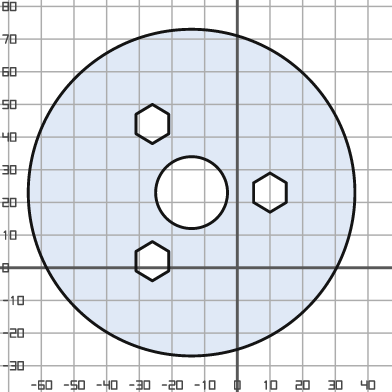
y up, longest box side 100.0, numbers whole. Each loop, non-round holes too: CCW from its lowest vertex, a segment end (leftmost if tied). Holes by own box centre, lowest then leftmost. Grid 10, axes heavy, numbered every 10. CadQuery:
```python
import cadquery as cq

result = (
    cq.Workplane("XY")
    .moveTo(-14.0, 23.0)
    .circle(50.0)
    .moveTo(-26.0, -4.0)
    .lineTo(-21.0, -1.0)
    .lineTo(-21.0, 5.0)
    .lineTo(-26.0, 8.0)
    .lineTo(-31.0, 5.0)
    .lineTo(-31.0, -1.0)
    .close()
    .moveTo(-14.0, 23.0)
    .circle(11.0)
    .moveTo(10.0, 17.0)
    .lineTo(15.0, 20.0)
    .lineTo(15.0, 26.0)
    .lineTo(10.0, 29.0)
    .lineTo(5.0, 26.0)
    .lineTo(5.0, 20.0)
    .close()
    .moveTo(-26.0, 38.0)
    .lineTo(-21.0, 41.0)
    .lineTo(-21.0, 47.0)
    .lineTo(-26.0, 50.0)
    .lineTo(-31.0, 47.0)
    .lineTo(-31.0, 41.0)
    .close()
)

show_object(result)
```